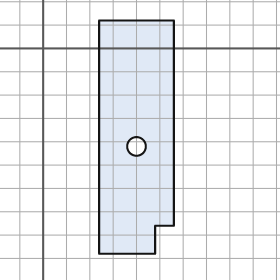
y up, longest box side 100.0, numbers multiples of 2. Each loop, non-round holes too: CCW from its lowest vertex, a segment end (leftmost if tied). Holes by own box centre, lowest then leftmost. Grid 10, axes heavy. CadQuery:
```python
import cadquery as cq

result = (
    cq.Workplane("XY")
    .moveTo(24.0, -88.0)
    .lineTo(48.0, -88.0)
    .lineTo(48.0, -76.0)
    .lineTo(56.0, -76.0)
    .lineTo(56.0, 12.0)
    .lineTo(24.0, 12.0)
    .close()
    .moveTo(40.0, -42.0)
    .circle(4.0)
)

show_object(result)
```